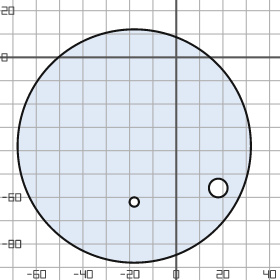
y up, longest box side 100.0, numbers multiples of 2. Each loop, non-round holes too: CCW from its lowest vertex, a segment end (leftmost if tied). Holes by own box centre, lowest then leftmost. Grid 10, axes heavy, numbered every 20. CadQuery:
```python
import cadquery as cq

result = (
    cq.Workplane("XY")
    .moveTo(-18.0, -38.0)
    .circle(50.0)
    .moveTo(-18.0, -62.0)
    .circle(2.0)
    .moveTo(18.0, -56.0)
    .circle(4.0)
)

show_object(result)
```